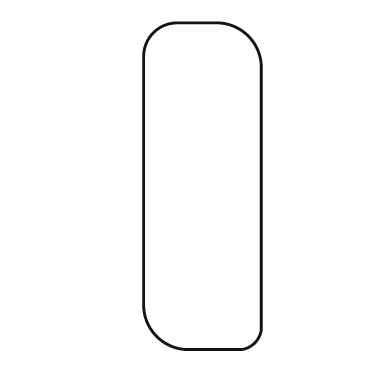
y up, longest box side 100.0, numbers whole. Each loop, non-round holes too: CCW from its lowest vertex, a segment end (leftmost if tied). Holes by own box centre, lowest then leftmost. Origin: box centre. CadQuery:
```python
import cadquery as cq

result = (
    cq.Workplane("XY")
    .moveTo(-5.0, -50.0)
    .lineTo(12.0, -50.0)
    .threePointArc((16.0, -48.0), (18.0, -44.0))
    .lineTo(18.0, 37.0)
    .threePointArc((14.0, 46.0), (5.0, 50.0))
    .lineTo(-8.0, 50.0)
    .threePointArc((-15.0, 47.0), (-18.0, 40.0))
    .lineTo(-18.0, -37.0)
    .threePointArc((-14.0, -46.0), (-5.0, -50.0))
    .close()
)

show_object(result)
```